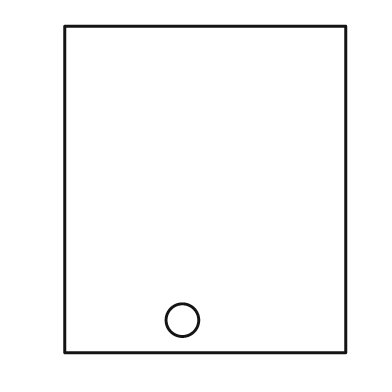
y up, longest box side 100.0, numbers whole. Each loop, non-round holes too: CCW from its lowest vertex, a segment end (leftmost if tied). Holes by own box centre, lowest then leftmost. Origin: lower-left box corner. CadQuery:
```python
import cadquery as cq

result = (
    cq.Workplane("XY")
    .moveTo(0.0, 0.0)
    .lineTo(86.0, 0.0)
    .lineTo(86.0, 100.0)
    .lineTo(0.0, 100.0)
    .close()
    .moveTo(36.0, 10.0)
    .circle(5.0)
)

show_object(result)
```